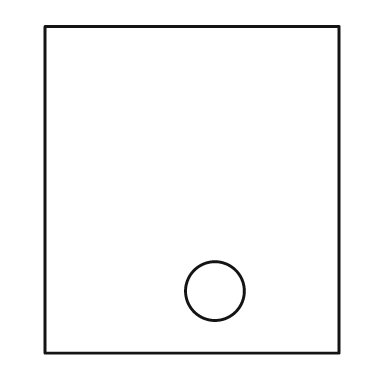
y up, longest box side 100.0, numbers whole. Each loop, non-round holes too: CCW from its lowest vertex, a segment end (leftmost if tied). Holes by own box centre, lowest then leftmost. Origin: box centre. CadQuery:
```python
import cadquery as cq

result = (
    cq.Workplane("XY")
    .moveTo(-45.0, -50.0)
    .lineTo(45.0, -50.0)
    .lineTo(45.0, 50.0)
    .lineTo(-45.0, 50.0)
    .close()
    .moveTo(7.0, -31.0)
    .circle(9.0)
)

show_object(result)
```